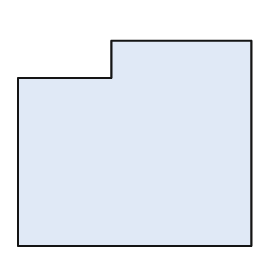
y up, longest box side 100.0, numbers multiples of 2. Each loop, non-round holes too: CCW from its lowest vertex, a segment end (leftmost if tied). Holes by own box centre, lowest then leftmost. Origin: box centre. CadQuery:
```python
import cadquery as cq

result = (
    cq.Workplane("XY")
    .moveTo(-50.0, -44.0)
    .lineTo(50.0, -44.0)
    .lineTo(50.0, 44.0)
    .lineTo(-10.0, 44.0)
    .lineTo(-10.0, 28.0)
    .lineTo(-50.0, 28.0)
    .close()
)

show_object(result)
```